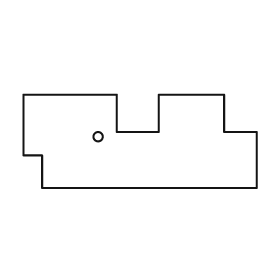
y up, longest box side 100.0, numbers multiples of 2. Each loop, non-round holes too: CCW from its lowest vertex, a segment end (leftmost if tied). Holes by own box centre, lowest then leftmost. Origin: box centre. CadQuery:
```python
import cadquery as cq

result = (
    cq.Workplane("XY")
    .moveTo(-42.0, -20.0)
    .lineTo(50.0, -20.0)
    .lineTo(50.0, 4.0)
    .lineTo(36.0, 4.0)
    .lineTo(36.0, 20.0)
    .lineTo(8.0, 20.0)
    .lineTo(8.0, 4.0)
    .lineTo(-10.0, 4.0)
    .lineTo(-10.0, 20.0)
    .lineTo(-50.0, 20.0)
    .lineTo(-50.0, -6.0)
    .lineTo(-42.0, -6.0)
    .close()
    .moveTo(-18.0, 2.0)
    .circle(2.0)
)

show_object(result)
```